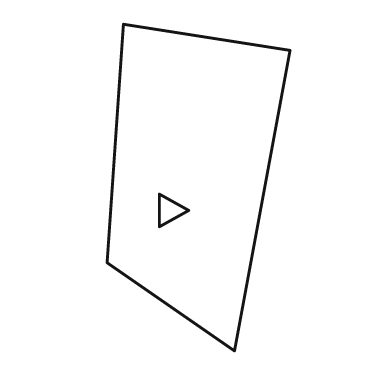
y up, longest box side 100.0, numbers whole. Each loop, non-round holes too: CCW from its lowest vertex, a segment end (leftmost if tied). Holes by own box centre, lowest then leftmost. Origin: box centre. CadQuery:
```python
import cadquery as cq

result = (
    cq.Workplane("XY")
    .moveTo(11.0, -50.0)
    .lineTo(28.0, 42.0)
    .lineTo(-23.0, 50.0)
    .lineTo(-28.0, -23.0)
    .close()
    .moveTo(-12.0, -12.0)
    .lineTo(-3.0, -7.0)
    .lineTo(-12.0, -2.0)
    .close()
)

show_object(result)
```